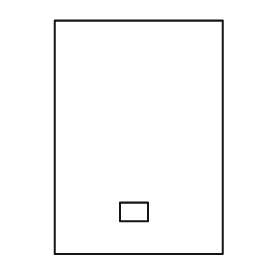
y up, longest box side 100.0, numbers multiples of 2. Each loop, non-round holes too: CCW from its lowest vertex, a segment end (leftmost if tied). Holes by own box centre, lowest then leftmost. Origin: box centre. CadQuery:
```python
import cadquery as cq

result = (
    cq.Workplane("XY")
    .moveTo(-36.0, -50.0)
    .lineTo(36.0, -50.0)
    .lineTo(36.0, 50.0)
    .lineTo(-36.0, 50.0)
    .close()
    .moveTo(-8.0, -36.0)
    .lineTo(4.0, -36.0)
    .lineTo(4.0, -28.0)
    .lineTo(-8.0, -28.0)
    .close()
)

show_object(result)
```